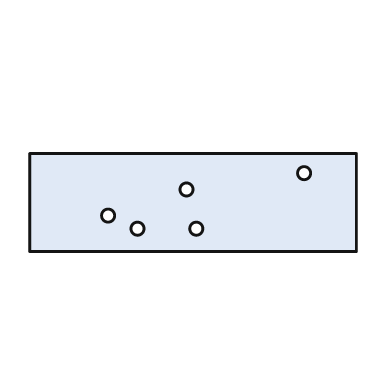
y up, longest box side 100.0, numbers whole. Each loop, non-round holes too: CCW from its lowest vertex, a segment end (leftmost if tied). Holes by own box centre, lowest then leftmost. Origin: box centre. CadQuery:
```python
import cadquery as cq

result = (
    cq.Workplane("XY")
    .moveTo(-50.0, -15.0)
    .lineTo(50.0, -15.0)
    .lineTo(50.0, 15.0)
    .lineTo(-50.0, 15.0)
    .close()
    .moveTo(-17.0, -8.0)
    .circle(2.0)
    .moveTo(1.0, -8.0)
    .circle(2.0)
    .moveTo(-26.0, -4.0)
    .circle(2.0)
    .moveTo(-2.0, 4.0)
    .circle(2.0)
    .moveTo(34.0, 9.0)
    .circle(2.0)
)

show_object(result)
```